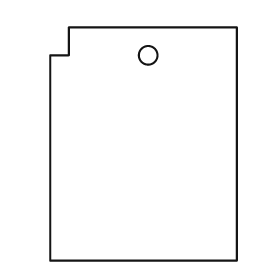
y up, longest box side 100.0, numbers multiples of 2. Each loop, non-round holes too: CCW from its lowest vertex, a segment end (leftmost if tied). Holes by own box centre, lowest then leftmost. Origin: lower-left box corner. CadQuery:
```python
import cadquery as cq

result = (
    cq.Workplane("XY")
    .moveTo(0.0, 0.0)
    .lineTo(80.0, 0.0)
    .lineTo(80.0, 100.0)
    .lineTo(8.0, 100.0)
    .lineTo(8.0, 88.0)
    .lineTo(0.0, 88.0)
    .close()
    .moveTo(42.0, 88.0)
    .circle(4.0)
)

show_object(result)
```